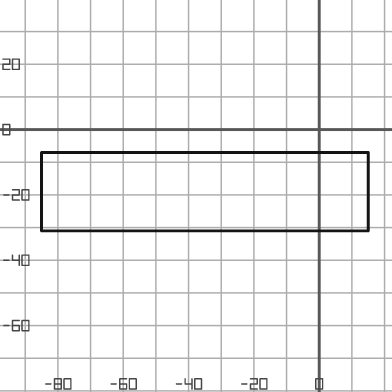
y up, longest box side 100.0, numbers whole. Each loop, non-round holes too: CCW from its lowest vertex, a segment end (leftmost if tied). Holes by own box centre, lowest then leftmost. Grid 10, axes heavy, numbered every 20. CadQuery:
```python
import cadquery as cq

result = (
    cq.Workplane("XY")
    .moveTo(-85.0, -31.0)
    .lineTo(15.0, -31.0)
    .lineTo(15.0, -7.0)
    .lineTo(-85.0, -7.0)
    .close()
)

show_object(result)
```